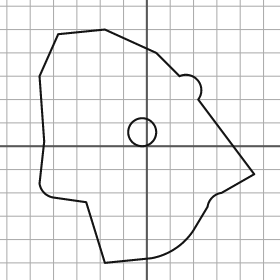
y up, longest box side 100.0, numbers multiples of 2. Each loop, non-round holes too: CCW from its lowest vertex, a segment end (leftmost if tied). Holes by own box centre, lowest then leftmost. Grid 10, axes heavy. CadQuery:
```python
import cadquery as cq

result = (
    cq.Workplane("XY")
    .moveTo(-18.0, -50.0)
    .lineTo(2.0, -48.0)
    .threePointArc((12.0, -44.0), (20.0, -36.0))
    .lineTo(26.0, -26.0)
    .threePointArc((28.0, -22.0), (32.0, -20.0))
    .lineTo(46.0, -12.0)
    .lineTo(22.0, 20.0)
    .threePointArc((22.0, 28.0), (14.0, 30.0))
    .lineTo(4.0, 40.0)
    .lineTo(-18.0, 50.0)
    .lineTo(-38.0, 48.0)
    .lineTo(-46.0, 30.0)
    .lineTo(-44.0, 2.0)
    .lineTo(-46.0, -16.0)
    .threePointArc((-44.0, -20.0), (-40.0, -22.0))
    .lineTo(-26.0, -24.0)
    .close()
    .moveTo(-2.0, 6.0)
    .circle(6.0)
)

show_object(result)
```